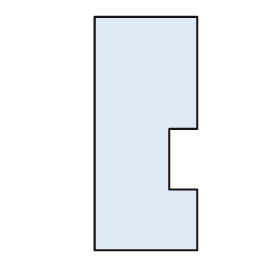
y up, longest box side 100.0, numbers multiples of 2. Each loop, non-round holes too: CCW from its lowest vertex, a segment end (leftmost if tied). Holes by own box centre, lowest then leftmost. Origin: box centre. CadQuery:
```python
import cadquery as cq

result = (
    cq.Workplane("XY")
    .moveTo(-22.0, -50.0)
    .lineTo(22.0, -50.0)
    .lineTo(22.0, -24.0)
    .lineTo(10.0, -24.0)
    .lineTo(10.0, 2.0)
    .lineTo(22.0, 2.0)
    .lineTo(22.0, 50.0)
    .lineTo(-22.0, 50.0)
    .close()
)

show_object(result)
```